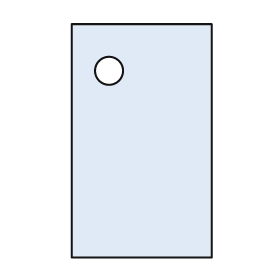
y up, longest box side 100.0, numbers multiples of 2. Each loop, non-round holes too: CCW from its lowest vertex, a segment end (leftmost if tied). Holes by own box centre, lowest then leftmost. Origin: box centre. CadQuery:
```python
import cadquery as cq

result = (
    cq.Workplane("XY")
    .moveTo(-30.0, -50.0)
    .lineTo(30.0, -50.0)
    .lineTo(30.0, 50.0)
    .lineTo(-30.0, 50.0)
    .close()
    .moveTo(-14.0, 30.0)
    .circle(6.0)
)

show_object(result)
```